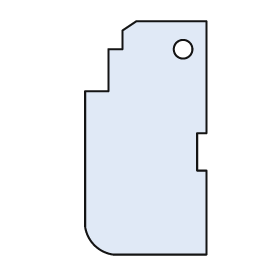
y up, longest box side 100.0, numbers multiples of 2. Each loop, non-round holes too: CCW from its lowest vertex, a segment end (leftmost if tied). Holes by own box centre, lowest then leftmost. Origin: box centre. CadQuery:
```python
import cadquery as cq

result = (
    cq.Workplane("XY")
    .moveTo(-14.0, -50.0)
    .lineTo(26.0, -50.0)
    .lineTo(26.0, -14.0)
    .lineTo(22.0, -14.0)
    .lineTo(22.0, 2.0)
    .lineTo(26.0, 2.0)
    .lineTo(26.0, 50.0)
    .lineTo(-4.0, 50.0)
    .lineTo(-10.0, 46.0)
    .lineTo(-10.0, 38.0)
    .lineTo(-16.0, 38.0)
    .lineTo(-16.0, 20.0)
    .lineTo(-26.0, 20.0)
    .lineTo(-26.0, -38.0)
    .threePointArc((-22.0, -46.0), (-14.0, -50.0))
    .close()
    .moveTo(16.0, 38.0)
    .circle(4.0)
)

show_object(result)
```